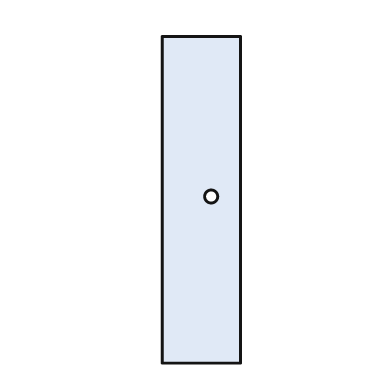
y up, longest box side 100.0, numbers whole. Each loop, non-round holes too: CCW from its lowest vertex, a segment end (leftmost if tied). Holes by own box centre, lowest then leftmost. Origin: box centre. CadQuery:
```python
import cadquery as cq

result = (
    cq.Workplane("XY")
    .moveTo(-12.0, -50.0)
    .lineTo(12.0, -50.0)
    .lineTo(12.0, 50.0)
    .lineTo(-12.0, 50.0)
    .close()
    .moveTo(3.0, 1.0)
    .circle(2.0)
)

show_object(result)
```